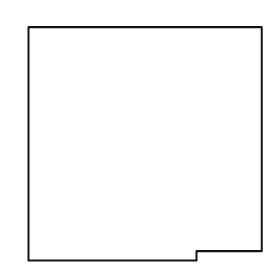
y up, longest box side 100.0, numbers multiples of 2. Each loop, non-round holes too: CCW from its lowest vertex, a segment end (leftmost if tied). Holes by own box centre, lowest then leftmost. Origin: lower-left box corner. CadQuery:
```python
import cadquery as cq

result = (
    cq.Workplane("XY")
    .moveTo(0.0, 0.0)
    .lineTo(72.0, 0.0)
    .lineTo(72.0, 4.0)
    .lineTo(100.0, 4.0)
    .lineTo(100.0, 100.0)
    .lineTo(0.0, 100.0)
    .close()
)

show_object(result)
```